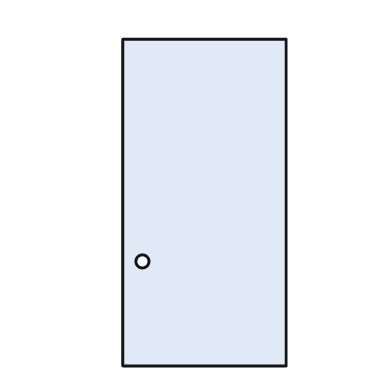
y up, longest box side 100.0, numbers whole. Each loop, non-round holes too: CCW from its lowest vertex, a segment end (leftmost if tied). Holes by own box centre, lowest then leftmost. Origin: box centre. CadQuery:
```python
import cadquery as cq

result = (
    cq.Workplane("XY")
    .moveTo(-25.0, -50.0)
    .lineTo(25.0, -50.0)
    .lineTo(25.0, 50.0)
    .lineTo(-25.0, 50.0)
    .close()
    .moveTo(-19.0, -18.0)
    .circle(2.0)
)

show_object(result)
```